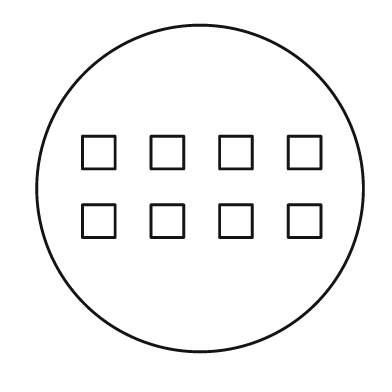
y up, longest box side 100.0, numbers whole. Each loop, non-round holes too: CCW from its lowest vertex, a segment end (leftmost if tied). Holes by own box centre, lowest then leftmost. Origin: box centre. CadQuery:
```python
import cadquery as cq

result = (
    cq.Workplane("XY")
    .moveTo(0.0, 0.0)
    .circle(50.0)
    .moveTo(-36.0, -15.0)
    .lineTo(-26.0, -15.0)
    .lineTo(-26.0, -5.0)
    .lineTo(-36.0, -5.0)
    .close()
    .moveTo(-15.0, -15.0)
    .lineTo(-5.0, -15.0)
    .lineTo(-5.0, -5.0)
    .lineTo(-15.0, -5.0)
    .close()
    .moveTo(6.0, -15.0)
    .lineTo(16.0, -15.0)
    .lineTo(16.0, -5.0)
    .lineTo(6.0, -5.0)
    .close()
    .moveTo(27.0, -15.0)
    .lineTo(37.0, -15.0)
    .lineTo(37.0, -5.0)
    .lineTo(27.0, -5.0)
    .close()
    .moveTo(-36.0, 6.0)
    .lineTo(-26.0, 6.0)
    .lineTo(-26.0, 16.0)
    .lineTo(-36.0, 16.0)
    .close()
    .moveTo(-15.0, 6.0)
    .lineTo(-5.0, 6.0)
    .lineTo(-5.0, 16.0)
    .lineTo(-15.0, 16.0)
    .close()
    .moveTo(6.0, 6.0)
    .lineTo(16.0, 6.0)
    .lineTo(16.0, 16.0)
    .lineTo(6.0, 16.0)
    .close()
    .moveTo(27.0, 6.0)
    .lineTo(37.0, 6.0)
    .lineTo(37.0, 16.0)
    .lineTo(27.0, 16.0)
    .close()
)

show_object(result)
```